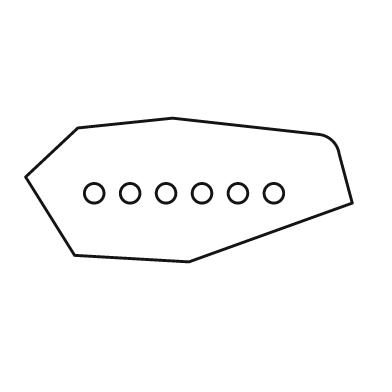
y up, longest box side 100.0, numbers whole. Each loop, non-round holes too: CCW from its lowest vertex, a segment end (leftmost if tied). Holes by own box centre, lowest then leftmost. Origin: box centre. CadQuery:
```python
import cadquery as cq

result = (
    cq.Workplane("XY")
    .moveTo(0.0, -22.0)
    .lineTo(50.0, -4.0)
    .lineTo(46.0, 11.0)
    .threePointArc((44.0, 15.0), (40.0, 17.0))
    .lineTo(-5.0, 22.0)
    .lineTo(-34.0, 19.0)
    .lineTo(-50.0, 4.0)
    .lineTo(-35.0, -20.0)
    .close()
    .moveTo(-29.0, -1.0)
    .circle(3.0)
    .moveTo(-18.0, -1.0)
    .circle(3.0)
    .moveTo(-7.0, -1.0)
    .circle(3.0)
    .moveTo(4.0, -1.0)
    .circle(3.0)
    .moveTo(15.0, -1.0)
    .circle(3.0)
    .moveTo(26.0, -1.0)
    .circle(3.0)
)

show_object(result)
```